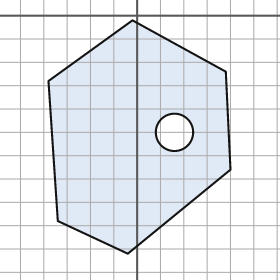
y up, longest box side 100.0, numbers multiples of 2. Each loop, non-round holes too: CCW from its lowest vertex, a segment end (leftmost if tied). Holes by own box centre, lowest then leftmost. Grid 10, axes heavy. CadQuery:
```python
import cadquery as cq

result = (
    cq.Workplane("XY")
    .moveTo(-4.0, -102.0)
    .lineTo(40.0, -66.0)
    .lineTo(38.0, -24.0)
    .lineTo(-2.0, -2.0)
    .lineTo(-38.0, -28.0)
    .lineTo(-34.0, -88.0)
    .close()
    .moveTo(16.0, -50.0)
    .circle(8.0)
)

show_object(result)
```